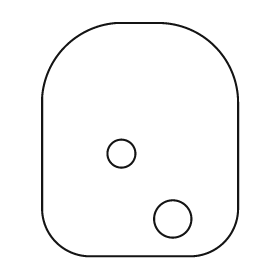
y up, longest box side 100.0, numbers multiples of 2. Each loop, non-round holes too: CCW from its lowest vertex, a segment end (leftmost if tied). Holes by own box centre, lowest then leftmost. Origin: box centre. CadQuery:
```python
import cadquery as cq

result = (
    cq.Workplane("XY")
    .moveTo(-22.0, -50.0)
    .lineTo(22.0, -50.0)
    .threePointArc((36.0, -44.0), (42.0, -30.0))
    .lineTo(42.0, 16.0)
    .threePointArc((32.0, 40.0), (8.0, 50.0))
    .lineTo(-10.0, 50.0)
    .threePointArc((-32.0, 40.0), (-42.0, 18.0))
    .lineTo(-42.0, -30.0)
    .threePointArc((-36.0, -44.0), (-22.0, -50.0))
    .close()
    .moveTo(14.0, -34.0)
    .circle(8.0)
    .moveTo(-8.0, -6.0)
    .circle(6.0)
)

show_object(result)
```